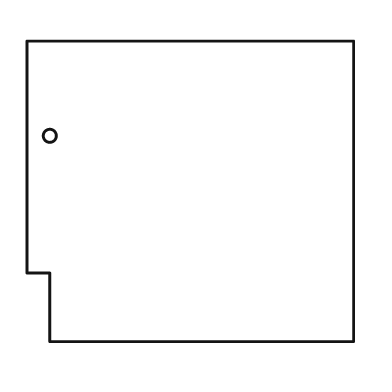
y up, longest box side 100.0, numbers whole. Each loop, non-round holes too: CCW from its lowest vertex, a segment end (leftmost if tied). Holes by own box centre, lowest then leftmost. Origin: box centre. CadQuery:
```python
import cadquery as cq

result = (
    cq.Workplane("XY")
    .moveTo(-43.0, -46.0)
    .lineTo(50.0, -46.0)
    .lineTo(50.0, 46.0)
    .lineTo(-50.0, 46.0)
    .lineTo(-50.0, -25.0)
    .lineTo(-43.0, -25.0)
    .close()
    .moveTo(-43.0, 17.0)
    .circle(2.0)
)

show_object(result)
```